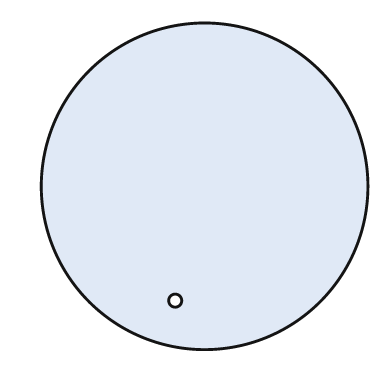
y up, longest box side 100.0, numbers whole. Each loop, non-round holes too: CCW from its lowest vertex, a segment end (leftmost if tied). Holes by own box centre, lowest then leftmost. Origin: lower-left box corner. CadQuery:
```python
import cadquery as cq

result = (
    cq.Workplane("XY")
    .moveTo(50.0, 50.0)
    .circle(50.0)
    .moveTo(41.0, 15.0)
    .circle(2.0)
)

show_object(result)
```